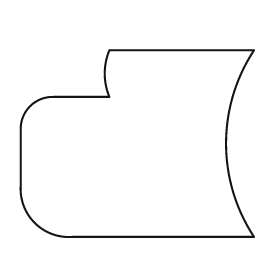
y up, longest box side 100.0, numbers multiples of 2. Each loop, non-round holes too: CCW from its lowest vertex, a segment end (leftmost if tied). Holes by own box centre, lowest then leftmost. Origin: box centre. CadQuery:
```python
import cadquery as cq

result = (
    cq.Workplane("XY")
    .moveTo(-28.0, -40.0)
    .lineTo(50.0, -40.0)
    .threePointArc((38.0, 0.0), (50.0, 40.0))
    .lineTo(-12.0, 40.0)
    .threePointArc((-14.0, 30.0), (-12.0, 20.0))
    .lineTo(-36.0, 20.0)
    .threePointArc((-46.0, 16.0), (-50.0, 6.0))
    .lineTo(-50.0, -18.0)
    .threePointArc((-44.0, -34.0), (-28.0, -40.0))
    .close()
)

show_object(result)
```